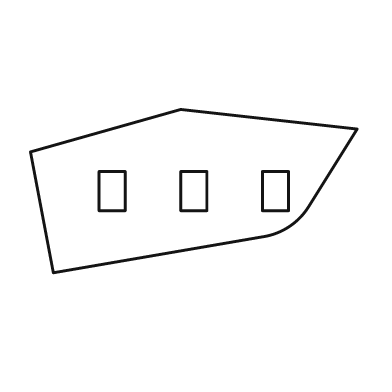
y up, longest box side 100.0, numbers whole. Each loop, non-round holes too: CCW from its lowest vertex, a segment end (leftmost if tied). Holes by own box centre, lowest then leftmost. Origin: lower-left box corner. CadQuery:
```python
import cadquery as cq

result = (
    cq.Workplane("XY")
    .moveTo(7.0, 0.0)
    .lineTo(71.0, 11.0)
    .threePointArc((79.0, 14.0), (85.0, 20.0))
    .lineTo(100.0, 44.0)
    .lineTo(46.0, 50.0)
    .lineTo(0.0, 37.0)
    .close()
    .moveTo(21.0, 19.0)
    .lineTo(29.0, 19.0)
    .lineTo(29.0, 31.0)
    .lineTo(21.0, 31.0)
    .close()
    .moveTo(46.0, 19.0)
    .lineTo(54.0, 19.0)
    .lineTo(54.0, 31.0)
    .lineTo(46.0, 31.0)
    .close()
    .moveTo(71.0, 19.0)
    .lineTo(79.0, 19.0)
    .lineTo(79.0, 31.0)
    .lineTo(71.0, 31.0)
    .close()
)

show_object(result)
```